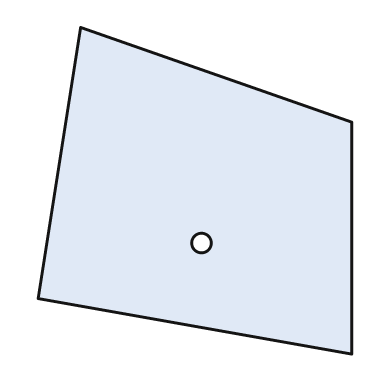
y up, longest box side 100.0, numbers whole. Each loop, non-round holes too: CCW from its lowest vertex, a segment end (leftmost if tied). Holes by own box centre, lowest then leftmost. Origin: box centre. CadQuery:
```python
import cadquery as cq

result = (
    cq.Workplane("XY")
    .moveTo(48.0, -50.0)
    .lineTo(48.0, 21.0)
    .lineTo(-35.0, 50.0)
    .lineTo(-48.0, -33.0)
    .close()
    .moveTo(2.0, -16.0)
    .circle(3.0)
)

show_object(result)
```